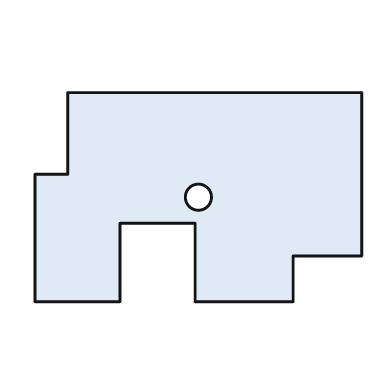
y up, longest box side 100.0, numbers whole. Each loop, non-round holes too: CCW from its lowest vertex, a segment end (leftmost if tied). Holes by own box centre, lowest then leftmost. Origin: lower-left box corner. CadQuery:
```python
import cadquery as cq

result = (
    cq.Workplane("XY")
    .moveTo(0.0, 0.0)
    .lineTo(26.0, 0.0)
    .lineTo(26.0, 24.0)
    .lineTo(49.0, 24.0)
    .lineTo(49.0, 0.0)
    .lineTo(79.0, 0.0)
    .lineTo(79.0, 14.0)
    .lineTo(100.0, 14.0)
    .lineTo(100.0, 64.0)
    .lineTo(10.0, 64.0)
    .lineTo(10.0, 39.0)
    .lineTo(0.0, 39.0)
    .close()
    .moveTo(50.0, 32.0)
    .circle(4.0)
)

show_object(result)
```